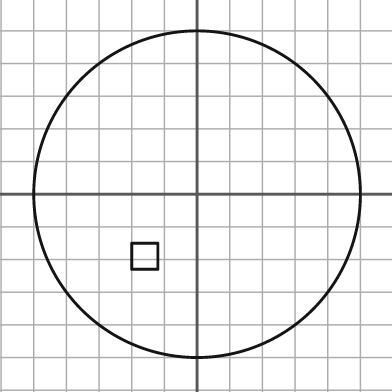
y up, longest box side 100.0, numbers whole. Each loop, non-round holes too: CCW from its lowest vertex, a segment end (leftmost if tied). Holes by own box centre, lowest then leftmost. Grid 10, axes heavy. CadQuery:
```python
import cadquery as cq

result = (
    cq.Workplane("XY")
    .moveTo(0.0, 0.0)
    .circle(50.0)
    .moveTo(-20.0, -23.0)
    .lineTo(-12.0, -23.0)
    .lineTo(-12.0, -15.0)
    .lineTo(-20.0, -15.0)
    .close()
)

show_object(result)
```